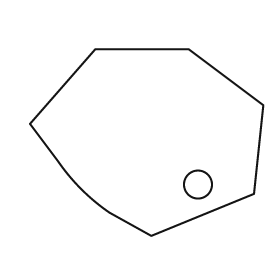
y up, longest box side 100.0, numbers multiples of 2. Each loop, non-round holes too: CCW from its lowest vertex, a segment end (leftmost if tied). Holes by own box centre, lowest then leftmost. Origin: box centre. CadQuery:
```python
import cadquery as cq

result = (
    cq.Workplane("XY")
    .moveTo(2.0, -40.0)
    .lineTo(46.0, -22.0)
    .lineTo(50.0, 16.0)
    .lineTo(18.0, 40.0)
    .lineTo(-22.0, 40.0)
    .lineTo(-50.0, 8.0)
    .lineTo(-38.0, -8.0)
    .threePointArc((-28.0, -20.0), (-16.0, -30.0))
    .close()
    .moveTo(22.0, -18.0)
    .circle(6.0)
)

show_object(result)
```